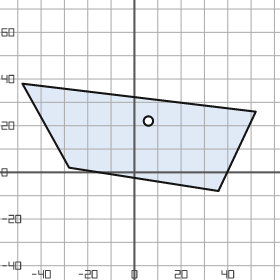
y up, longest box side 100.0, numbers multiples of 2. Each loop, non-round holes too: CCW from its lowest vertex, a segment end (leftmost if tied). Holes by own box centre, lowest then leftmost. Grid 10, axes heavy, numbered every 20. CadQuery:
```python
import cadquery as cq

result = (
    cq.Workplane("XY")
    .moveTo(36.0, -8.0)
    .lineTo(52.0, 26.0)
    .lineTo(-48.0, 38.0)
    .lineTo(-28.0, 2.0)
    .close()
    .moveTo(6.0, 22.0)
    .circle(2.0)
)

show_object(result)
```